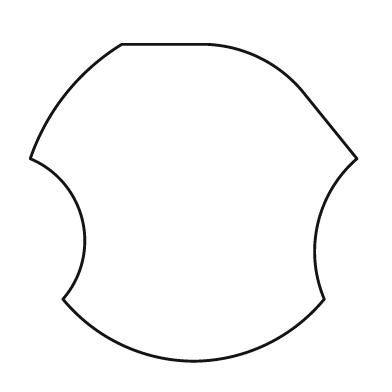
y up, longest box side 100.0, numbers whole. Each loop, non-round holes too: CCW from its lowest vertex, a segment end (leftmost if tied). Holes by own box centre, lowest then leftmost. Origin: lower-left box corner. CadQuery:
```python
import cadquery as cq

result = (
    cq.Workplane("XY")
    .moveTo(50.0, 0.0)
    .threePointArc((72.0, 5.0), (90.0, 19.0))
    .threePointArc((88.0, 42.0), (100.0, 62.0))
    .lineTo(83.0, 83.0)
    .threePointArc((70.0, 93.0), (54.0, 97.0))
    .lineTo(28.0, 97.0)
    .threePointArc((11.0, 82.0), (0.0, 62.0))
    .threePointArc((16.0, 43.0), (10.0, 19.0))
    .threePointArc((28.0, 5.0), (50.0, 0.0))
    .close()
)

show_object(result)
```